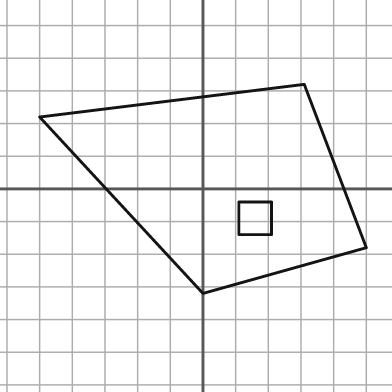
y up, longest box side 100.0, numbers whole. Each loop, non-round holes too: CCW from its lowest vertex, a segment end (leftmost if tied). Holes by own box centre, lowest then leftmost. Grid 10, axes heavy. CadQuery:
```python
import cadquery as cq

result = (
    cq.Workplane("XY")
    .moveTo(0.0, -32.0)
    .lineTo(50.0, -18.0)
    .lineTo(31.0, 32.0)
    .lineTo(-50.0, 22.0)
    .close()
    .moveTo(11.0, -14.0)
    .lineTo(21.0, -14.0)
    .lineTo(21.0, -4.0)
    .lineTo(11.0, -4.0)
    .close()
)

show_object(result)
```